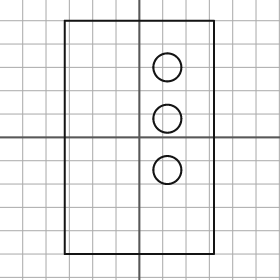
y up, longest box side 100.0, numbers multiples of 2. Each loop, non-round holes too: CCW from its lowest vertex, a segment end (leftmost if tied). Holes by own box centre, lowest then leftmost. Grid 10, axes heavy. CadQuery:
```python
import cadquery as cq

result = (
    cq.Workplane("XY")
    .moveTo(-32.0, -50.0)
    .lineTo(32.0, -50.0)
    .lineTo(32.0, 50.0)
    .lineTo(-32.0, 50.0)
    .close()
    .moveTo(12.0, -14.0)
    .circle(6.0)
    .moveTo(12.0, 8.0)
    .circle(6.0)
    .moveTo(12.0, 30.0)
    .circle(6.0)
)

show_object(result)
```